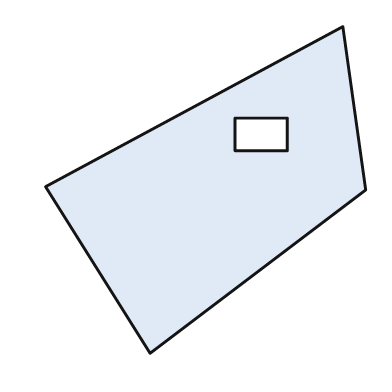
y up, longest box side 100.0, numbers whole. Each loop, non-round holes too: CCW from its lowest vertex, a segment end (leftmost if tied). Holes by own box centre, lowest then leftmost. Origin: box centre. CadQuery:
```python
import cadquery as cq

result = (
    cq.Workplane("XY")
    .moveTo(-17.0, -50.0)
    .lineTo(49.0, 0.0)
    .lineTo(42.0, 50.0)
    .lineTo(-49.0, 1.0)
    .close()
    .moveTo(9.0, 12.0)
    .lineTo(25.0, 12.0)
    .lineTo(25.0, 22.0)
    .lineTo(9.0, 22.0)
    .close()
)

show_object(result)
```